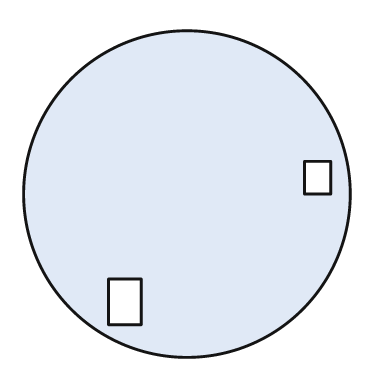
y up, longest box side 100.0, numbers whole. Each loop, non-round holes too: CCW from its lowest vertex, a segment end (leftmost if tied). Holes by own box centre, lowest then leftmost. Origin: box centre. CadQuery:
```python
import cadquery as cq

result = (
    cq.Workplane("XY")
    .moveTo(0.0, 0.0)
    .circle(50.0)
    .moveTo(-24.0, -40.0)
    .lineTo(-14.0, -40.0)
    .lineTo(-14.0, -26.0)
    .lineTo(-24.0, -26.0)
    .close()
    .moveTo(36.0, 0.0)
    .lineTo(44.0, 0.0)
    .lineTo(44.0, 10.0)
    .lineTo(36.0, 10.0)
    .close()
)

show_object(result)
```